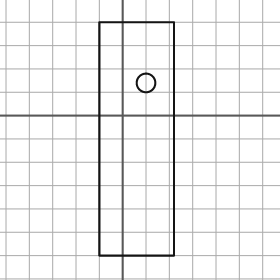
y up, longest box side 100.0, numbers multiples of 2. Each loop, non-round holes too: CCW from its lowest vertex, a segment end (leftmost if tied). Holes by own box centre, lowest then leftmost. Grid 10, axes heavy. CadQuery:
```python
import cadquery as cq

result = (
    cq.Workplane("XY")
    .moveTo(-10.0, -60.0)
    .lineTo(22.0, -60.0)
    .lineTo(22.0, 40.0)
    .lineTo(-10.0, 40.0)
    .close()
    .moveTo(10.0, 14.0)
    .circle(4.0)
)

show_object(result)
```